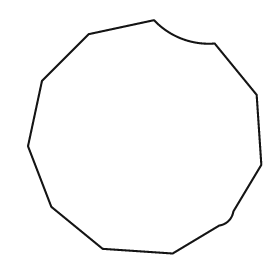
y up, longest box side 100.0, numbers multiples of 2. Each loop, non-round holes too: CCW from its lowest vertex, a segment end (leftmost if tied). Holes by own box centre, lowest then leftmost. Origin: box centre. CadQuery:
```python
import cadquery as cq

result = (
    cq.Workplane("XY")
    .moveTo(12.0, -50.0)
    .lineTo(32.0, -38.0)
    .threePointArc((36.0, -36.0), (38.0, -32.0))
    .lineTo(50.0, -12.0)
    .lineTo(48.0, 18.0)
    .lineTo(30.0, 40.0)
    .threePointArc((16.0, 42.0), (4.0, 50.0))
    .lineTo(-24.0, 44.0)
    .lineTo(-44.0, 24.0)
    .lineTo(-50.0, -4.0)
    .lineTo(-40.0, -30.0)
    .lineTo(-18.0, -48.0)
    .close()
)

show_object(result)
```